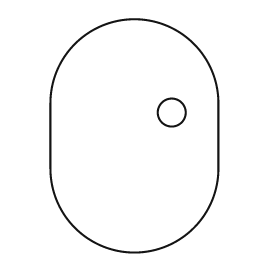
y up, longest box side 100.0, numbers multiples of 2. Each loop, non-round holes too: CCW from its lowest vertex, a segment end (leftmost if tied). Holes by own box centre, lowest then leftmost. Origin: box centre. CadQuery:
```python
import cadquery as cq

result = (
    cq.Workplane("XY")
    .moveTo(-36.0, -14.0)
    .threePointArc((0.0, -50.0), (36.0, -14.0))
    .lineTo(36.0, 14.0)
    .threePointArc((0.0, 50.0), (-36.0, 14.0))
    .close()
    .moveTo(16.0, 10.0)
    .circle(6.0)
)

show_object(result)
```